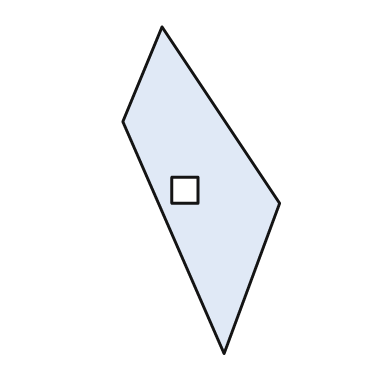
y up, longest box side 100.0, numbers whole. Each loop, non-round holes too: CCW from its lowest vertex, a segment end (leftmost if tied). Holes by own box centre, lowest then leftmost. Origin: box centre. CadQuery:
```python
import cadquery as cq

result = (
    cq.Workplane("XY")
    .moveTo(7.0, -50.0)
    .lineTo(24.0, -4.0)
    .lineTo(-12.0, 50.0)
    .lineTo(-24.0, 21.0)
    .close()
    .moveTo(-9.0, -4.0)
    .lineTo(-1.0, -4.0)
    .lineTo(-1.0, 4.0)
    .lineTo(-9.0, 4.0)
    .close()
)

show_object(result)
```